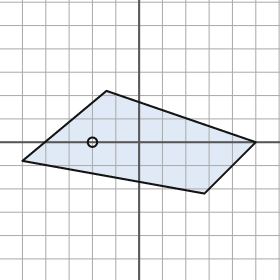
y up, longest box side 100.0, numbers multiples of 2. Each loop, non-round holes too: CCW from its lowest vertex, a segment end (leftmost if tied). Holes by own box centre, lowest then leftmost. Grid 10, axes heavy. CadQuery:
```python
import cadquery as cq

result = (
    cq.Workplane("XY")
    .moveTo(28.0, -22.0)
    .lineTo(50.0, 0.0)
    .lineTo(-14.0, 22.0)
    .lineTo(-50.0, -8.0)
    .close()
    .moveTo(-20.0, 0.0)
    .circle(2.0)
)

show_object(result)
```